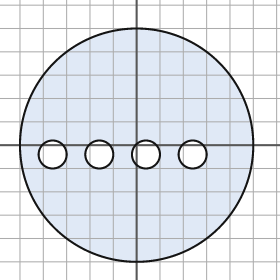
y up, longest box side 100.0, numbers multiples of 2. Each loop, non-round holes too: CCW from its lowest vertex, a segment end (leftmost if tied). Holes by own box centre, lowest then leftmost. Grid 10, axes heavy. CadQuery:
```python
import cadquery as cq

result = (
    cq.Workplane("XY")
    .moveTo(0.0, 0.0)
    .circle(50.0)
    .moveTo(-36.0, -4.0)
    .circle(6.0)
    .moveTo(-16.0, -4.0)
    .circle(6.0)
    .moveTo(4.0, -4.0)
    .circle(6.0)
    .moveTo(24.0, -4.0)
    .circle(6.0)
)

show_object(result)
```